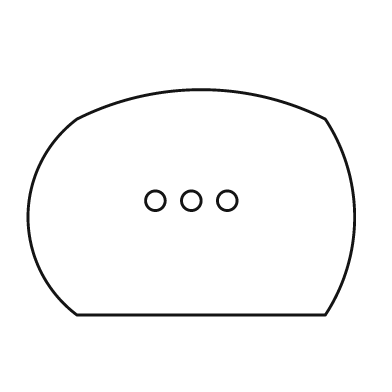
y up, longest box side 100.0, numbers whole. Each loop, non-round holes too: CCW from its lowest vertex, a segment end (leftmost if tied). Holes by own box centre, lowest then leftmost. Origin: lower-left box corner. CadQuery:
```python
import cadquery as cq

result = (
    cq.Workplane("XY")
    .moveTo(15.0, 0.0)
    .lineTo(91.0, 0.0)
    .threePointArc((100.0, 30.0), (91.0, 60.0))
    .threePointArc((53.0, 69.0), (15.0, 60.0))
    .threePointArc((0.0, 30.0), (15.0, 0.0))
    .close()
    .moveTo(39.0, 35.0)
    .circle(3.0)
    .moveTo(50.0, 35.0)
    .circle(3.0)
    .moveTo(61.0, 35.0)
    .circle(3.0)
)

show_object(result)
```